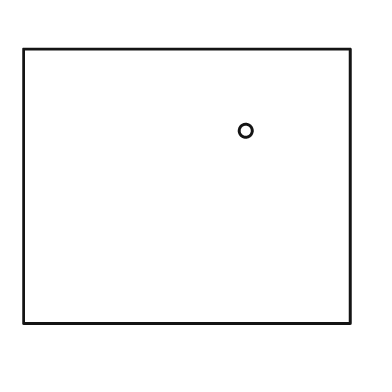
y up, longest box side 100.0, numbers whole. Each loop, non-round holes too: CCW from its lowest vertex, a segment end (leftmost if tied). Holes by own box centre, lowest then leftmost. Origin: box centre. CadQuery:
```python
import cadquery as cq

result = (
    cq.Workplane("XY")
    .moveTo(-50.0, -42.0)
    .lineTo(50.0, -42.0)
    .lineTo(50.0, 42.0)
    .lineTo(-50.0, 42.0)
    .close()
    .moveTo(18.0, 17.0)
    .circle(2.0)
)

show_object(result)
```